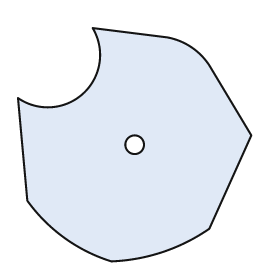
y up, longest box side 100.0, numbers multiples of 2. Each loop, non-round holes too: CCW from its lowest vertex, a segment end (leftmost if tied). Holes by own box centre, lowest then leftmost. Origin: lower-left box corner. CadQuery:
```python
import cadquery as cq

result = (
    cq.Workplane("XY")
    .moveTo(40.0, 0.0)
    .threePointArc((62.0, 4.0), (82.0, 14.0))
    .lineTo(100.0, 54.0)
    .lineTo(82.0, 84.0)
    .threePointArc((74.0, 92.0), (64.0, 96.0))
    .lineTo(32.0, 100.0)
    .threePointArc((28.0, 72.0), (0.0, 70.0))
    .lineTo(4.0, 26.0)
    .threePointArc((20.0, 10.0), (40.0, 0.0))
    .close()
    .moveTo(50.0, 50.0)
    .circle(4.0)
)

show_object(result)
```